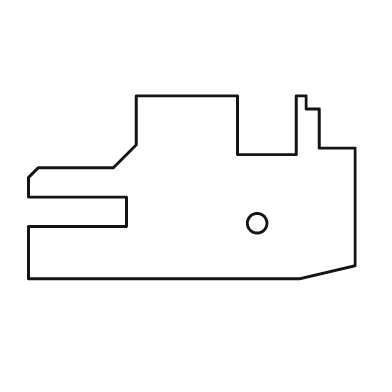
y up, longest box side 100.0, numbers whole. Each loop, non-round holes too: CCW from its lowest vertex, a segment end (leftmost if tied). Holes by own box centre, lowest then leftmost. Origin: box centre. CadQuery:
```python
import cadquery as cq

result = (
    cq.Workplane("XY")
    .moveTo(-50.0, -28.0)
    .lineTo(33.0, -28.0)
    .lineTo(50.0, -24.0)
    .lineTo(50.0, 12.0)
    .lineTo(39.0, 12.0)
    .lineTo(39.0, 24.0)
    .lineTo(35.0, 24.0)
    .lineTo(35.0, 28.0)
    .lineTo(32.0, 28.0)
    .lineTo(32.0, 10.0)
    .lineTo(14.0, 10.0)
    .lineTo(14.0, 28.0)
    .lineTo(-17.0, 28.0)
    .lineTo(-17.0, 13.0)
    .lineTo(-24.0, 6.0)
    .lineTo(-47.0, 6.0)
    .lineTo(-50.0, 3.0)
    .lineTo(-50.0, -3.0)
    .lineTo(-20.0, -3.0)
    .lineTo(-20.0, -12.0)
    .lineTo(-50.0, -12.0)
    .close()
    .moveTo(20.0, -11.0)
    .circle(3.0)
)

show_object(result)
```